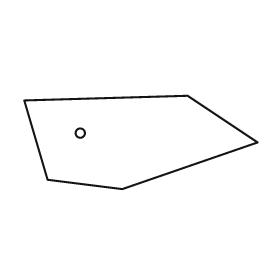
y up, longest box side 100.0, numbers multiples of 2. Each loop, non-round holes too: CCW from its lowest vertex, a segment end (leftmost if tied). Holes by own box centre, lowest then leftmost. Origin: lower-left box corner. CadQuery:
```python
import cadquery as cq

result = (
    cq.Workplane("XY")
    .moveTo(42.0, 0.0)
    .lineTo(100.0, 20.0)
    .lineTo(70.0, 40.0)
    .lineTo(0.0, 38.0)
    .lineTo(10.0, 4.0)
    .close()
    .moveTo(24.0, 24.0)
    .circle(2.0)
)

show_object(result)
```